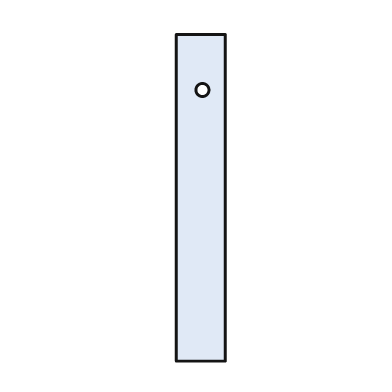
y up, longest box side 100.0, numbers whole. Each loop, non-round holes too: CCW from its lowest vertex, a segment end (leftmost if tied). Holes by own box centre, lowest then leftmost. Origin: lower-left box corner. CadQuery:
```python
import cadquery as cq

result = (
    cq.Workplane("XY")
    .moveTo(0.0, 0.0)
    .lineTo(15.0, 0.0)
    .lineTo(15.0, 100.0)
    .lineTo(0.0, 100.0)
    .close()
    .moveTo(8.0, 83.0)
    .circle(2.0)
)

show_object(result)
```